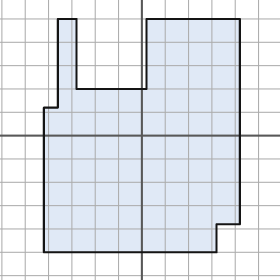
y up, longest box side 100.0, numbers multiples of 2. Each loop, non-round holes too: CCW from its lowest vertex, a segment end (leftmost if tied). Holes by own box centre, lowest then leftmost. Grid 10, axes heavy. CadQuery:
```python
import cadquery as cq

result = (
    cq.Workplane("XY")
    .moveTo(-42.0, -50.0)
    .lineTo(32.0, -50.0)
    .lineTo(32.0, -38.0)
    .lineTo(42.0, -38.0)
    .lineTo(42.0, 50.0)
    .lineTo(2.0, 50.0)
    .lineTo(2.0, 20.0)
    .lineTo(-28.0, 20.0)
    .lineTo(-28.0, 50.0)
    .lineTo(-36.0, 50.0)
    .lineTo(-36.0, 12.0)
    .lineTo(-42.0, 12.0)
    .close()
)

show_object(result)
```